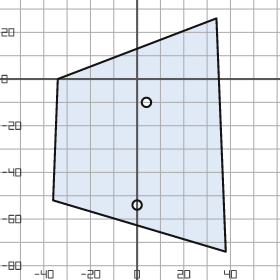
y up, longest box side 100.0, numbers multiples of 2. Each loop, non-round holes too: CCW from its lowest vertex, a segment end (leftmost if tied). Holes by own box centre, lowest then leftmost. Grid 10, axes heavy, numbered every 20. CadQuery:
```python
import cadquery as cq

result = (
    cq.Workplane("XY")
    .moveTo(38.0, -74.0)
    .lineTo(34.0, 26.0)
    .lineTo(-34.0, 0.0)
    .lineTo(-36.0, -52.0)
    .close()
    .moveTo(0.0, -54.0)
    .circle(2.0)
    .moveTo(4.0, -10.0)
    .circle(2.0)
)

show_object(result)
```